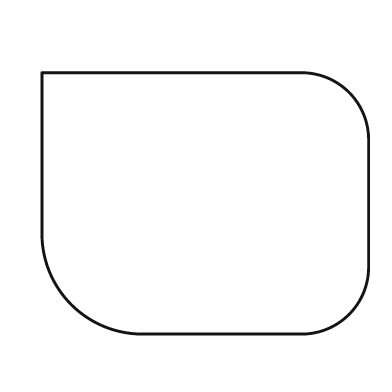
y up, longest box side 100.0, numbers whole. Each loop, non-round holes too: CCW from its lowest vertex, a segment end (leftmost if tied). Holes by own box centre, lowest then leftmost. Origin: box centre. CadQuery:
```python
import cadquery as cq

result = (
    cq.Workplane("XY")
    .moveTo(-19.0, -40.0)
    .lineTo(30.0, -40.0)
    .threePointArc((44.0, -34.0), (50.0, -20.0))
    .lineTo(50.0, 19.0)
    .threePointArc((44.0, 34.0), (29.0, 40.0))
    .lineTo(-50.0, 40.0)
    .lineTo(-50.0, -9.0)
    .threePointArc((-41.0, -31.0), (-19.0, -40.0))
    .close()
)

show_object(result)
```